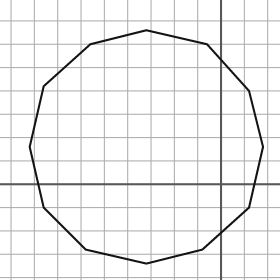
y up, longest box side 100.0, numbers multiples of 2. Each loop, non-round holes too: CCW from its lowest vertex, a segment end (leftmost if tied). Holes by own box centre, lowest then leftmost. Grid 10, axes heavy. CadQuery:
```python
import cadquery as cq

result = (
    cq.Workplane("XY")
    .moveTo(-32.0, -34.0)
    .lineTo(-8.0, -28.0)
    .lineTo(12.0, -10.0)
    .lineTo(18.0, 16.0)
    .lineTo(12.0, 40.0)
    .lineTo(-6.0, 60.0)
    .lineTo(-32.0, 66.0)
    .lineTo(-56.0, 60.0)
    .lineTo(-76.0, 42.0)
    .lineTo(-82.0, 16.0)
    .lineTo(-76.0, -10.0)
    .lineTo(-58.0, -28.0)
    .close()
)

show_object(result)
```